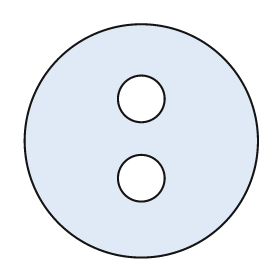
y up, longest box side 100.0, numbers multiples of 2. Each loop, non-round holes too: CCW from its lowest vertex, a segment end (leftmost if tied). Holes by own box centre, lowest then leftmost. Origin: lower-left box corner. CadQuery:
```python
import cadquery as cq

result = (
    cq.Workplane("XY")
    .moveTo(50.0, 50.0)
    .circle(50.0)
    .moveTo(50.0, 34.0)
    .circle(10.0)
    .moveTo(50.0, 68.0)
    .circle(10.0)
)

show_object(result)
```